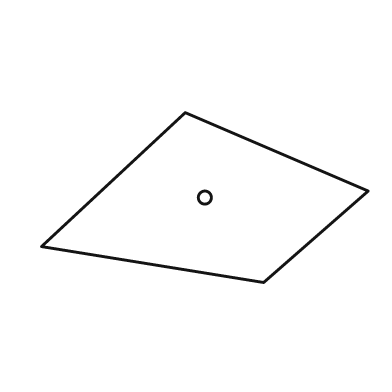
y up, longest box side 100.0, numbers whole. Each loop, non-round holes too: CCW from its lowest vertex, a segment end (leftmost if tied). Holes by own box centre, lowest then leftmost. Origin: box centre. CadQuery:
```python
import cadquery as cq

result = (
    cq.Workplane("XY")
    .moveTo(18.0, -26.0)
    .lineTo(50.0, 2.0)
    .lineTo(-6.0, 26.0)
    .lineTo(-50.0, -15.0)
    .close()
    .moveTo(0.0, 0.0)
    .circle(2.0)
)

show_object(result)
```